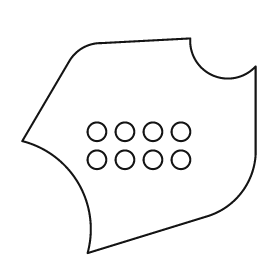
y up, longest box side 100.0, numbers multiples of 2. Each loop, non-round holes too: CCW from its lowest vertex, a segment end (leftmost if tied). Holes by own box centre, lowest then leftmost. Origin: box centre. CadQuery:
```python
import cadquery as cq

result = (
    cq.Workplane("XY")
    .moveTo(-22.0, -46.0)
    .lineTo(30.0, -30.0)
    .threePointArc((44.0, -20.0), (50.0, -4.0))
    .lineTo(50.0, 34.0)
    .threePointArc((32.0, 30.0), (22.0, 46.0))
    .lineTo(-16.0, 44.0)
    .threePointArc((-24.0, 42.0), (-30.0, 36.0))
    .lineTo(-50.0, 2.0)
    .threePointArc((-26.0, -16.0), (-22.0, -46.0))
    .close()
    .moveTo(-18.0, -6.0)
    .circle(4.0)
    .moveTo(-6.0, -6.0)
    .circle(4.0)
    .moveTo(6.0, -6.0)
    .circle(4.0)
    .moveTo(18.0, -6.0)
    .circle(4.0)
    .moveTo(-18.0, 6.0)
    .circle(4.0)
    .moveTo(-6.0, 6.0)
    .circle(4.0)
    .moveTo(6.0, 6.0)
    .circle(4.0)
    .moveTo(18.0, 6.0)
    .circle(4.0)
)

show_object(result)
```